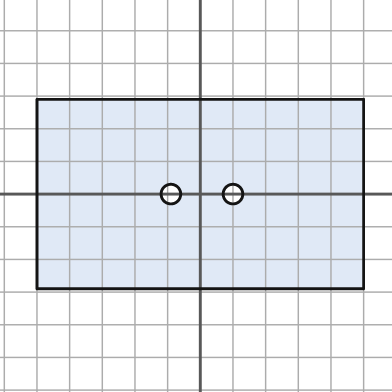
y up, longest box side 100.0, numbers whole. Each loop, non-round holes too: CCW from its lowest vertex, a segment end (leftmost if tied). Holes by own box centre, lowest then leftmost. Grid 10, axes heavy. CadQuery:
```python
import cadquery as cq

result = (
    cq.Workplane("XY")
    .moveTo(-50.0, -29.0)
    .lineTo(50.0, -29.0)
    .lineTo(50.0, 29.0)
    .lineTo(-50.0, 29.0)
    .close()
    .moveTo(-9.0, 0.0)
    .circle(3.0)
    .moveTo(10.0, 0.0)
    .circle(3.0)
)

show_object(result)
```